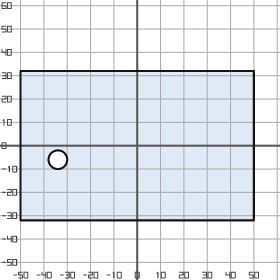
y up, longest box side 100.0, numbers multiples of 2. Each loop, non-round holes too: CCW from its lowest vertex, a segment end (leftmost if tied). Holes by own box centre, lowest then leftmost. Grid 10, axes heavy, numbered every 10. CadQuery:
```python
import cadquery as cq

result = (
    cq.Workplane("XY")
    .moveTo(-50.0, -32.0)
    .lineTo(50.0, -32.0)
    .lineTo(50.0, 32.0)
    .lineTo(-50.0, 32.0)
    .close()
    .moveTo(-34.0, -6.0)
    .circle(4.0)
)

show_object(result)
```